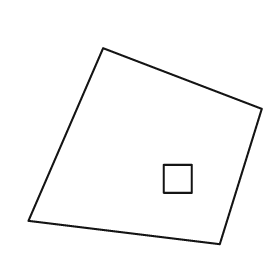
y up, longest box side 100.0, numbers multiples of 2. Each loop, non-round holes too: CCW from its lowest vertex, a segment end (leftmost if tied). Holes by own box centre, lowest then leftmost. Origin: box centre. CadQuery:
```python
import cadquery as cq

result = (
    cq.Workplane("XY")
    .moveTo(32.0, -42.0)
    .lineTo(50.0, 16.0)
    .lineTo(-18.0, 42.0)
    .lineTo(-50.0, -32.0)
    .close()
    .moveTo(8.0, -20.0)
    .lineTo(20.0, -20.0)
    .lineTo(20.0, -8.0)
    .lineTo(8.0, -8.0)
    .close()
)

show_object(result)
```